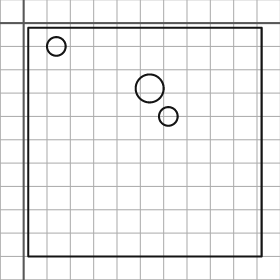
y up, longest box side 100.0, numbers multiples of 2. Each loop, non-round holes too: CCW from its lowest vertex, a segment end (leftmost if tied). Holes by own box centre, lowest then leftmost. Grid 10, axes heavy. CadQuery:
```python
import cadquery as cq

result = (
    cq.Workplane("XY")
    .moveTo(2.0, -100.0)
    .lineTo(102.0, -100.0)
    .lineTo(102.0, -2.0)
    .lineTo(2.0, -2.0)
    .close()
    .moveTo(62.0, -40.0)
    .circle(4.0)
    .moveTo(54.0, -28.0)
    .circle(6.0)
    .moveTo(14.0, -10.0)
    .circle(4.0)
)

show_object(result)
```